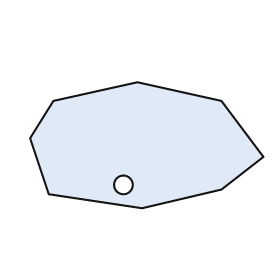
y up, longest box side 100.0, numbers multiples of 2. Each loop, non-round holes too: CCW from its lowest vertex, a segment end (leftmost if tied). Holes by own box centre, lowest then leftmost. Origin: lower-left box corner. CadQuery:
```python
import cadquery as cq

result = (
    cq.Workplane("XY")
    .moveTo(48.0, 0.0)
    .lineTo(82.0, 8.0)
    .lineTo(100.0, 22.0)
    .lineTo(82.0, 46.0)
    .lineTo(46.0, 54.0)
    .lineTo(10.0, 46.0)
    .lineTo(0.0, 30.0)
    .lineTo(8.0, 6.0)
    .close()
    .moveTo(40.0, 10.0)
    .circle(4.0)
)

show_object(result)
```